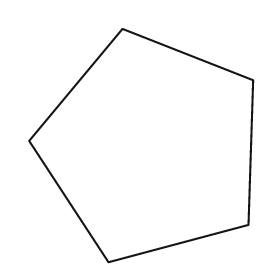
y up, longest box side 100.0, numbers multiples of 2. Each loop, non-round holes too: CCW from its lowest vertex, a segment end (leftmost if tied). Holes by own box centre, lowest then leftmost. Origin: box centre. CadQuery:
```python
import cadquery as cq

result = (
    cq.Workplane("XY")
    .moveTo(-14.0, -50.0)
    .lineTo(46.0, -34.0)
    .lineTo(48.0, 28.0)
    .lineTo(-8.0, 50.0)
    .lineTo(-48.0, 2.0)
    .close()
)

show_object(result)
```